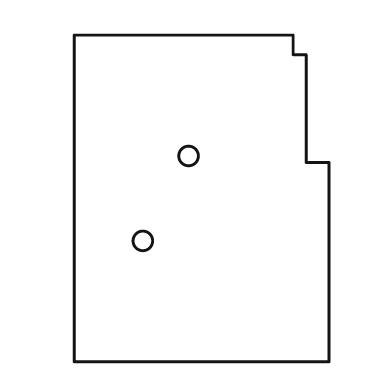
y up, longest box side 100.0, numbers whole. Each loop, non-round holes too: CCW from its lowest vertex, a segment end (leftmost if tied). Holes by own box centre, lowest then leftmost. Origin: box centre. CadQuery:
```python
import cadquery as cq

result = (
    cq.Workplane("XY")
    .moveTo(-39.0, -50.0)
    .lineTo(39.0, -50.0)
    .lineTo(39.0, 11.0)
    .lineTo(32.0, 11.0)
    .lineTo(32.0, 44.0)
    .lineTo(28.0, 44.0)
    .lineTo(28.0, 50.0)
    .lineTo(-39.0, 50.0)
    .close()
    .moveTo(-18.0, -13.0)
    .circle(3.0)
    .moveTo(-4.0, 13.0)
    .circle(3.0)
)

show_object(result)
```